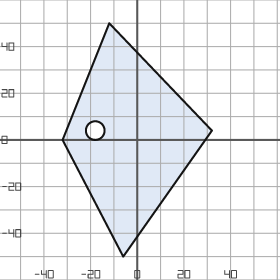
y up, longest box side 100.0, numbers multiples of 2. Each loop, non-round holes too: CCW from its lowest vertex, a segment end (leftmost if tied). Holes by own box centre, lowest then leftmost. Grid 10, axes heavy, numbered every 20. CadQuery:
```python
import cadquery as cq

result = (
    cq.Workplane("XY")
    .moveTo(-6.0, -50.0)
    .lineTo(32.0, 4.0)
    .lineTo(-12.0, 50.0)
    .lineTo(-32.0, 0.0)
    .close()
    .moveTo(-18.0, 4.0)
    .circle(4.0)
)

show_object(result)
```